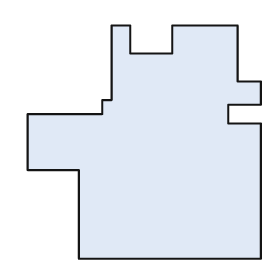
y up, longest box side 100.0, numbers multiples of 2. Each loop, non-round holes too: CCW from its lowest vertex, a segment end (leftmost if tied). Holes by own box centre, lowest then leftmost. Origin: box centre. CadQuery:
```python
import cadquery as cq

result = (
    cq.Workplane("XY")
    .moveTo(-28.0, -50.0)
    .lineTo(50.0, -50.0)
    .lineTo(50.0, 8.0)
    .lineTo(36.0, 8.0)
    .lineTo(36.0, 16.0)
    .lineTo(50.0, 16.0)
    .lineTo(50.0, 26.0)
    .lineTo(40.0, 26.0)
    .lineTo(40.0, 50.0)
    .lineTo(12.0, 50.0)
    .lineTo(12.0, 38.0)
    .lineTo(-6.0, 38.0)
    .lineTo(-6.0, 50.0)
    .lineTo(-14.0, 50.0)
    .lineTo(-14.0, 18.0)
    .lineTo(-18.0, 18.0)
    .lineTo(-18.0, 12.0)
    .lineTo(-50.0, 12.0)
    .lineTo(-50.0, -12.0)
    .lineTo(-28.0, -12.0)
    .close()
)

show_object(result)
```